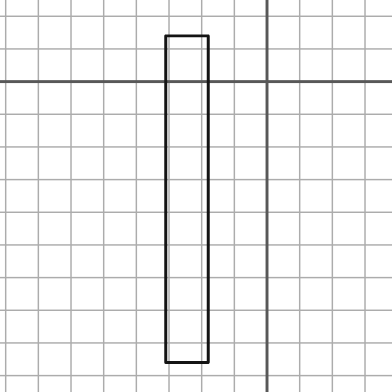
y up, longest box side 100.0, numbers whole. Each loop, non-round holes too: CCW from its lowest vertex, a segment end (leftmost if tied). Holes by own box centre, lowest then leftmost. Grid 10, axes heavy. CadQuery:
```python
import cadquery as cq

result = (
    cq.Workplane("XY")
    .moveTo(-31.0, -86.0)
    .lineTo(-18.0, -86.0)
    .lineTo(-18.0, 14.0)
    .lineTo(-31.0, 14.0)
    .close()
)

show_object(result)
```